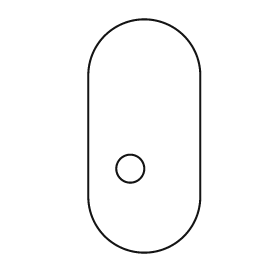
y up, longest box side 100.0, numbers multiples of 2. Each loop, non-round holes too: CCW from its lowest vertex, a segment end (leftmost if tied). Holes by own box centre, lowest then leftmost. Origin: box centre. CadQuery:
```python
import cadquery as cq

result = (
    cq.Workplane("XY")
    .moveTo(-24.0, -26.0)
    .threePointArc((0.0, -50.0), (24.0, -26.0))
    .lineTo(24.0, 26.0)
    .threePointArc((0.0, 50.0), (-24.0, 26.0))
    .close()
    .moveTo(-6.0, -14.0)
    .circle(6.0)
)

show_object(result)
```